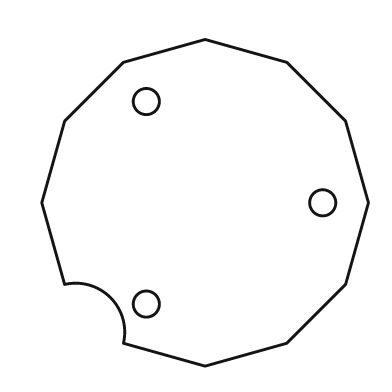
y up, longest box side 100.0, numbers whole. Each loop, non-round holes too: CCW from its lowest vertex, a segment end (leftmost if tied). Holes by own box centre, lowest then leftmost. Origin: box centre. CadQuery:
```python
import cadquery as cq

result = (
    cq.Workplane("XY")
    .moveTo(0.0, -50.0)
    .lineTo(25.0, -43.0)
    .lineTo(43.0, -25.0)
    .lineTo(50.0, 0.0)
    .lineTo(43.0, 25.0)
    .lineTo(25.0, 43.0)
    .lineTo(0.0, 50.0)
    .lineTo(-25.0, 43.0)
    .lineTo(-43.0, 25.0)
    .lineTo(-50.0, 0.0)
    .lineTo(-43.0, -25.0)
    .threePointArc((-29.0, -29.0), (-25.0, -43.0))
    .close()
    .moveTo(-18.0, -31.0)
    .circle(4.0)
    .moveTo(36.0, 0.0)
    .circle(4.0)
    .moveTo(-18.0, 31.0)
    .circle(4.0)
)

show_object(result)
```